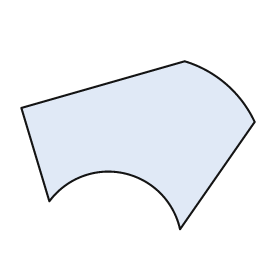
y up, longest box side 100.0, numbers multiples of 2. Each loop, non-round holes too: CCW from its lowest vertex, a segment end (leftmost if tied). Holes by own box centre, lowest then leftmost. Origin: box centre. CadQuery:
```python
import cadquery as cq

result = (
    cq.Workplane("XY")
    .moveTo(18.0, -36.0)
    .lineTo(50.0, 10.0)
    .threePointArc((38.0, 26.0), (20.0, 36.0))
    .lineTo(-50.0, 16.0)
    .lineTo(-38.0, -24.0)
    .threePointArc((-6.0, -12.0), (18.0, -36.0))
    .close()
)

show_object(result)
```